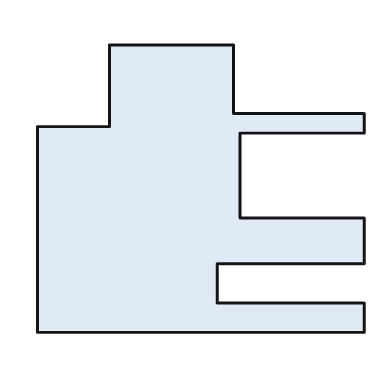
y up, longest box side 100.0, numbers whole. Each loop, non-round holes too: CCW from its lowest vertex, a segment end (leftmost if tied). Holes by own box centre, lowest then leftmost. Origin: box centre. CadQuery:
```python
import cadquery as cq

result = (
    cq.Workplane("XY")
    .moveTo(-50.0, -44.0)
    .lineTo(50.0, -44.0)
    .lineTo(50.0, -35.0)
    .lineTo(5.0, -35.0)
    .lineTo(5.0, -23.0)
    .lineTo(50.0, -23.0)
    .lineTo(50.0, -9.0)
    .lineTo(12.0, -9.0)
    .lineTo(12.0, 17.0)
    .lineTo(50.0, 17.0)
    .lineTo(50.0, 23.0)
    .lineTo(10.0, 23.0)
    .lineTo(10.0, 44.0)
    .lineTo(-28.0, 44.0)
    .lineTo(-28.0, 19.0)
    .lineTo(-50.0, 19.0)
    .close()
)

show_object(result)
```